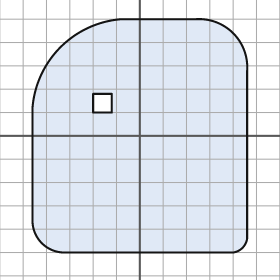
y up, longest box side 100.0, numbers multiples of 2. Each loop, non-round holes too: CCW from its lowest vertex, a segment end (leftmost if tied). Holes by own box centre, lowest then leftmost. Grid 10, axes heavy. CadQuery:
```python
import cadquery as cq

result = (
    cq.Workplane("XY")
    .moveTo(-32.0, -50.0)
    .lineTo(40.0, -50.0)
    .threePointArc((44.0, -48.0), (46.0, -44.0))
    .lineTo(46.0, 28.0)
    .threePointArc((40.0, 44.0), (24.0, 50.0))
    .lineTo(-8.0, 50.0)
    .threePointArc((-34.0, 38.0), (-46.0, 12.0))
    .lineTo(-46.0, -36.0)
    .threePointArc((-42.0, -46.0), (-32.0, -50.0))
    .close()
    .moveTo(-20.0, 10.0)
    .lineTo(-12.0, 10.0)
    .lineTo(-12.0, 18.0)
    .lineTo(-20.0, 18.0)
    .close()
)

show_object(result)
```